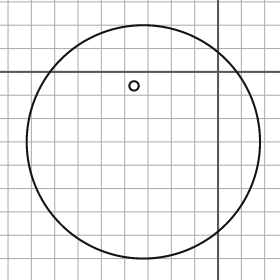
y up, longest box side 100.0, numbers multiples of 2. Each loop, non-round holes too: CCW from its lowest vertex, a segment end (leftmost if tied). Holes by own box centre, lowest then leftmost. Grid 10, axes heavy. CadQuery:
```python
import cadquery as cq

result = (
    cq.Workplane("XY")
    .moveTo(-32.0, -30.0)
    .circle(50.0)
    .moveTo(-36.0, -6.0)
    .circle(2.0)
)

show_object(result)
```